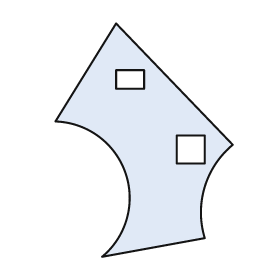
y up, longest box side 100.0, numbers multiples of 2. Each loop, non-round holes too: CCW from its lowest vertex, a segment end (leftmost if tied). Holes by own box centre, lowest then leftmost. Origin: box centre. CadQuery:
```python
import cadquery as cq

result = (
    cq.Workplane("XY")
    .moveTo(-18.0, -50.0)
    .lineTo(26.0, -42.0)
    .threePointArc((26.0, -20.0), (38.0, -2.0))
    .lineTo(-12.0, 50.0)
    .lineTo(-38.0, 8.0)
    .threePointArc((-8.0, -14.0), (-18.0, -50.0))
    .close()
    .moveTo(14.0, -10.0)
    .lineTo(26.0, -10.0)
    .lineTo(26.0, 2.0)
    .lineTo(14.0, 2.0)
    .close()
    .moveTo(-12.0, 22.0)
    .lineTo(0.0, 22.0)
    .lineTo(0.0, 30.0)
    .lineTo(-12.0, 30.0)
    .close()
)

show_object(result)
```